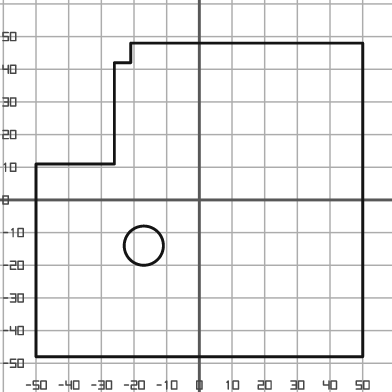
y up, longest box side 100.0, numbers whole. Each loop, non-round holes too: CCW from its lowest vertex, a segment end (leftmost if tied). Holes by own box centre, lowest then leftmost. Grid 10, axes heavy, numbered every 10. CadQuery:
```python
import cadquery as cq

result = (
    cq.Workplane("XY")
    .moveTo(-50.0, -48.0)
    .lineTo(50.0, -48.0)
    .lineTo(50.0, 48.0)
    .lineTo(-21.0, 48.0)
    .lineTo(-21.0, 42.0)
    .lineTo(-26.0, 42.0)
    .lineTo(-26.0, 11.0)
    .lineTo(-50.0, 11.0)
    .close()
    .moveTo(-17.0, -14.0)
    .circle(6.0)
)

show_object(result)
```